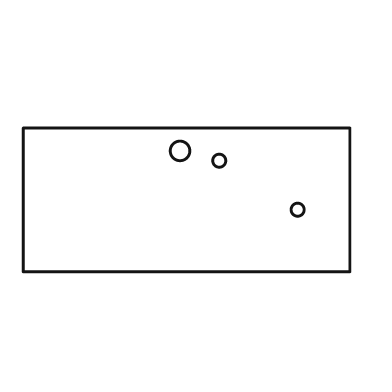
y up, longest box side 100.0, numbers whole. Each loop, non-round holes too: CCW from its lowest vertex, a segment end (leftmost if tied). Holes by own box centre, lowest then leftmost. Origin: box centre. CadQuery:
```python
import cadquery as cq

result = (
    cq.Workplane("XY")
    .moveTo(-50.0, -22.0)
    .lineTo(50.0, -22.0)
    .lineTo(50.0, 22.0)
    .lineTo(-50.0, 22.0)
    .close()
    .moveTo(34.0, -3.0)
    .circle(2.0)
    .moveTo(10.0, 12.0)
    .circle(2.0)
    .moveTo(-2.0, 15.0)
    .circle(3.0)
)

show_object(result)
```